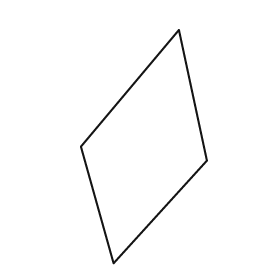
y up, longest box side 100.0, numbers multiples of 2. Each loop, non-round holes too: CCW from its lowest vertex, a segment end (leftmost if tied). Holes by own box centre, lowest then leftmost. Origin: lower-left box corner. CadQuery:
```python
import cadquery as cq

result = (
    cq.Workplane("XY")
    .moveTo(14.0, 0.0)
    .lineTo(54.0, 44.0)
    .lineTo(42.0, 100.0)
    .lineTo(0.0, 50.0)
    .close()
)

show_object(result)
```